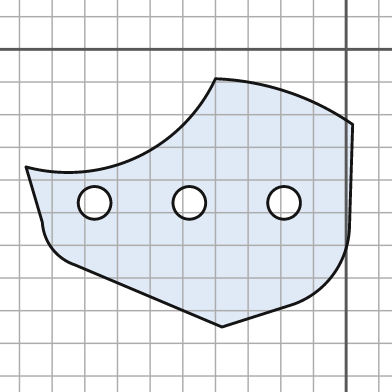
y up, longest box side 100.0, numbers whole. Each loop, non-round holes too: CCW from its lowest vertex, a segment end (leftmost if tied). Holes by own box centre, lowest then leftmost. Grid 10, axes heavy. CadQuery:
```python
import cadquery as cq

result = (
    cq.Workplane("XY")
    .moveTo(-38.0, -85.0)
    .lineTo(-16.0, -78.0)
    .threePointArc((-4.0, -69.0), (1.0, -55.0))
    .lineTo(2.0, -23.0)
    .threePointArc((-18.0, -13.0), (-40.0, -9.0))
    .threePointArc((-64.0, -33.0), (-98.0, -36.0))
    .lineTo(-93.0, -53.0)
    .threePointArc((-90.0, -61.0), (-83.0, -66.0))
    .close()
    .moveTo(-77.0, -47.0)
    .circle(5.0)
    .moveTo(-48.0, -47.0)
    .circle(5.0)
    .moveTo(-19.0, -47.0)
    .circle(5.0)
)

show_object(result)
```